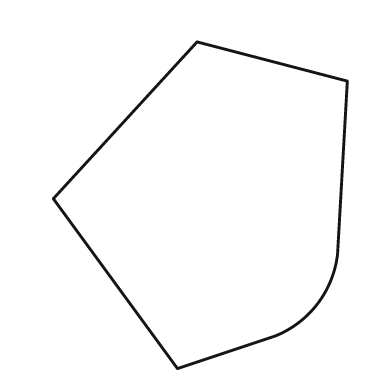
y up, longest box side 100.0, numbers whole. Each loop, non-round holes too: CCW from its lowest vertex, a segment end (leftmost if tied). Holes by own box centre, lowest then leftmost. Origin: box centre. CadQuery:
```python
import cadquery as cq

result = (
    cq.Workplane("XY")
    .moveTo(-7.0, -50.0)
    .lineTo(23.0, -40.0)
    .threePointArc((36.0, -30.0), (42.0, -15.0))
    .lineTo(45.0, 38.0)
    .lineTo(-1.0, 50.0)
    .lineTo(-45.0, 2.0)
    .close()
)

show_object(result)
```